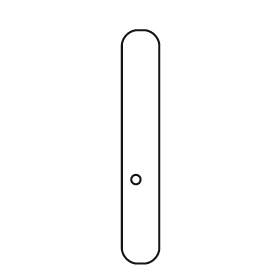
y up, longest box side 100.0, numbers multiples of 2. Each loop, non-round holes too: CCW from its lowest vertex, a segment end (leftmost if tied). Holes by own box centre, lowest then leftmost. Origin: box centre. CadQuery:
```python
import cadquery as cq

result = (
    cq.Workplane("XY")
    .moveTo(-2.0, -50.0)
    .lineTo(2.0, -50.0)
    .threePointArc((6.0, -48.0), (8.0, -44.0))
    .lineTo(8.0, 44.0)
    .threePointArc((6.0, 48.0), (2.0, 50.0))
    .lineTo(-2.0, 50.0)
    .threePointArc((-6.0, 48.0), (-8.0, 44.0))
    .lineTo(-8.0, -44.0)
    .threePointArc((-6.0, -48.0), (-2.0, -50.0))
    .close()
    .moveTo(-2.0, -14.0)
    .circle(2.0)
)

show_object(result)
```